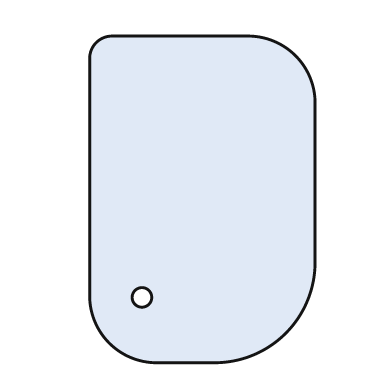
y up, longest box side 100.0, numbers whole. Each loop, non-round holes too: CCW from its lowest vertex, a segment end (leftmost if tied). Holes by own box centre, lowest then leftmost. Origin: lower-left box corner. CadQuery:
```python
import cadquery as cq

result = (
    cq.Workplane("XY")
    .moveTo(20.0, 0.0)
    .lineTo(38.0, 0.0)
    .threePointArc((60.0, 9.0), (69.0, 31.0))
    .lineTo(69.0, 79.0)
    .threePointArc((63.0, 94.0), (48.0, 100.0))
    .lineTo(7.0, 100.0)
    .threePointArc((2.0, 98.0), (0.0, 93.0))
    .lineTo(0.0, 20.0)
    .threePointArc((6.0, 6.0), (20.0, 0.0))
    .close()
    .moveTo(16.0, 20.0)
    .circle(3.0)
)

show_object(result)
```